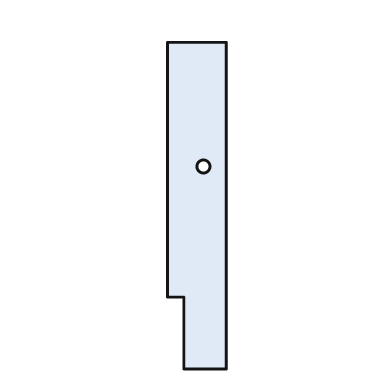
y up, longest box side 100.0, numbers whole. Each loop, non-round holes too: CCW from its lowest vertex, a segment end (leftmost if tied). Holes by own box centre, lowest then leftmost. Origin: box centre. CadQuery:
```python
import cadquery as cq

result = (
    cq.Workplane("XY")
    .moveTo(-4.0, -50.0)
    .lineTo(9.0, -50.0)
    .lineTo(9.0, 50.0)
    .lineTo(-9.0, 50.0)
    .lineTo(-9.0, -28.0)
    .lineTo(-4.0, -28.0)
    .close()
    .moveTo(2.0, 12.0)
    .circle(2.0)
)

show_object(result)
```